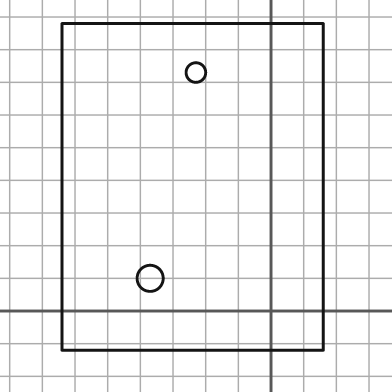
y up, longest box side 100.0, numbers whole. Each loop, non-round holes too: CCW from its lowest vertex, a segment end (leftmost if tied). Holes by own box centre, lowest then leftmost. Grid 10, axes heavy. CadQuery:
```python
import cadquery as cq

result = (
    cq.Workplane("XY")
    .moveTo(-64.0, -12.0)
    .lineTo(16.0, -12.0)
    .lineTo(16.0, 88.0)
    .lineTo(-64.0, 88.0)
    .close()
    .moveTo(-37.0, 10.0)
    .circle(4.0)
    .moveTo(-23.0, 73.0)
    .circle(3.0)
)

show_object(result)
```